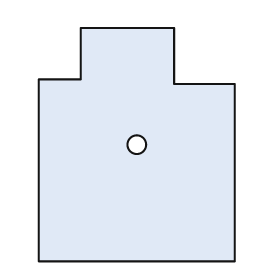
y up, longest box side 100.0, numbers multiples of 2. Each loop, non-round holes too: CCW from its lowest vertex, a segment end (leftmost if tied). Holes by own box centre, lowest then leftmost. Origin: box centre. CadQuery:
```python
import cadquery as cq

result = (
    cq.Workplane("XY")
    .moveTo(-42.0, -50.0)
    .lineTo(42.0, -50.0)
    .lineTo(42.0, 26.0)
    .lineTo(16.0, 26.0)
    .lineTo(16.0, 50.0)
    .lineTo(-24.0, 50.0)
    .lineTo(-24.0, 28.0)
    .lineTo(-42.0, 28.0)
    .close()
    .moveTo(0.0, 0.0)
    .circle(4.0)
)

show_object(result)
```